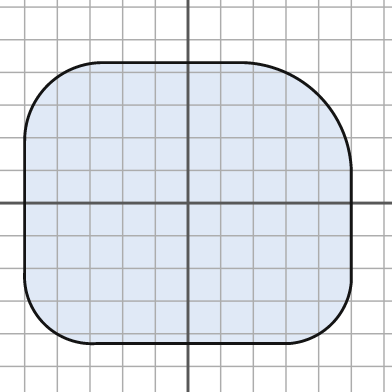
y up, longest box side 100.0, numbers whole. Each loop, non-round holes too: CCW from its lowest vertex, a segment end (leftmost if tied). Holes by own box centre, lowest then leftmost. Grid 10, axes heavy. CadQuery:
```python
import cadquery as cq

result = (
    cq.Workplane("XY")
    .moveTo(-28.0, -43.0)
    .lineTo(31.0, -43.0)
    .threePointArc((44.0, -37.0), (50.0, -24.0))
    .lineTo(50.0, 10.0)
    .threePointArc((40.0, 33.0), (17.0, 43.0))
    .lineTo(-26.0, 43.0)
    .threePointArc((-43.0, 36.0), (-50.0, 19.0))
    .lineTo(-50.0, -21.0)
    .threePointArc((-44.0, -37.0), (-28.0, -43.0))
    .close()
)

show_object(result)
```